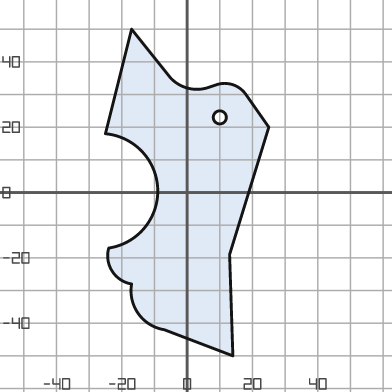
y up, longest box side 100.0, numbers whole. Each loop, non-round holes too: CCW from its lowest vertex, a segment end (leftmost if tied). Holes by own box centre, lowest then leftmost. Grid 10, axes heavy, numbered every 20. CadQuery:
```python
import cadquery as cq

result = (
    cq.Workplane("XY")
    .moveTo(14.0, -50.0)
    .lineTo(13.0, -19.0)
    .lineTo(25.0, 20.0)
    .lineTo(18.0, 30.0)
    .threePointArc((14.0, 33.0), (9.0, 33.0))
    .lineTo(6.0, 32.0)
    .threePointArc((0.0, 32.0), (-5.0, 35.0))
    .lineTo(-17.0, 50.0)
    .lineTo(-25.0, 18.0)
    .threePointArc((-9.0, 1.0), (-24.0, -17.0))
    .threePointArc((-23.0, -24.0), (-17.0, -28.0))
    .threePointArc((-15.0, -37.0), (-7.0, -42.0))
    .close()
    .moveTo(10.0, 23.0)
    .circle(2.0)
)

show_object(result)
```